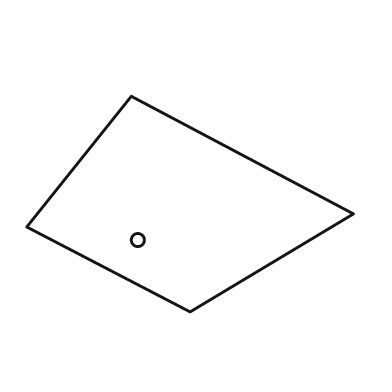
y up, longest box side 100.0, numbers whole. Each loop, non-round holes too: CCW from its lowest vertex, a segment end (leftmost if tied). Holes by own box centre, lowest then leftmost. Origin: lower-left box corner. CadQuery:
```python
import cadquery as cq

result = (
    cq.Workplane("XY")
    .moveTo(50.0, 0.0)
    .lineTo(100.0, 30.0)
    .lineTo(32.0, 66.0)
    .lineTo(0.0, 26.0)
    .close()
    .moveTo(34.0, 22.0)
    .circle(2.0)
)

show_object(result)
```